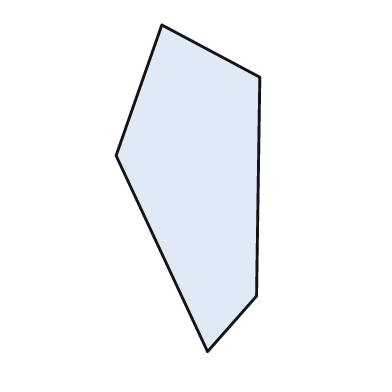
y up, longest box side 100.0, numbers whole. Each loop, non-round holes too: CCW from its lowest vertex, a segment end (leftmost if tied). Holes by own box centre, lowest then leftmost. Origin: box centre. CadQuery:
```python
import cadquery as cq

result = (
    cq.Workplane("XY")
    .moveTo(6.0, -50.0)
    .lineTo(21.0, -33.0)
    .lineTo(22.0, 34.0)
    .lineTo(-8.0, 50.0)
    .lineTo(-22.0, 10.0)
    .close()
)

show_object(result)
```